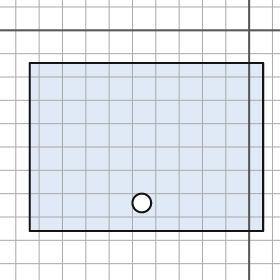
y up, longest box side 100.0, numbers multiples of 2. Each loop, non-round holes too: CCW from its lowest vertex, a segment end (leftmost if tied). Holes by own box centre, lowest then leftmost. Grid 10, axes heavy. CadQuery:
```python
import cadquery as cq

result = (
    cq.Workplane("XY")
    .moveTo(-94.0, -86.0)
    .lineTo(6.0, -86.0)
    .lineTo(6.0, -14.0)
    .lineTo(-94.0, -14.0)
    .close()
    .moveTo(-46.0, -74.0)
    .circle(4.0)
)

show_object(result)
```